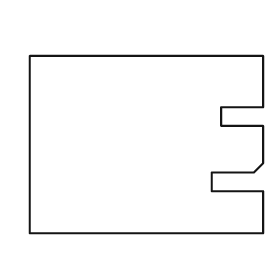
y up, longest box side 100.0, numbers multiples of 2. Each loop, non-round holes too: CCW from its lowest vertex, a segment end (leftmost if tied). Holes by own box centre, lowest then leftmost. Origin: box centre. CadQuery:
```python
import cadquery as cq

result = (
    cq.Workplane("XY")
    .moveTo(-50.0, -38.0)
    .lineTo(50.0, -38.0)
    .lineTo(50.0, -20.0)
    .lineTo(28.0, -20.0)
    .lineTo(28.0, -12.0)
    .lineTo(46.0, -12.0)
    .lineTo(50.0, -8.0)
    .lineTo(50.0, 8.0)
    .lineTo(32.0, 8.0)
    .lineTo(32.0, 16.0)
    .lineTo(50.0, 16.0)
    .lineTo(50.0, 38.0)
    .lineTo(-50.0, 38.0)
    .close()
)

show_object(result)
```